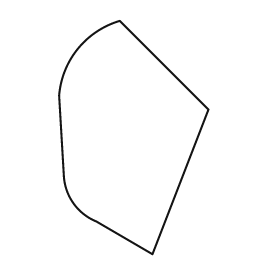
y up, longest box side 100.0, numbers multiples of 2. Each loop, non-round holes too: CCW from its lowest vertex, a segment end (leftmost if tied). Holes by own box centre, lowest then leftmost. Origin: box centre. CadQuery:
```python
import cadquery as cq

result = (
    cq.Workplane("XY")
    .moveTo(8.0, -50.0)
    .lineTo(32.0, 12.0)
    .lineTo(-6.0, 50.0)
    .threePointArc((-24.0, 38.0), (-32.0, 18.0))
    .lineTo(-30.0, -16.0)
    .threePointArc((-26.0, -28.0), (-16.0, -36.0))
    .close()
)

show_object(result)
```